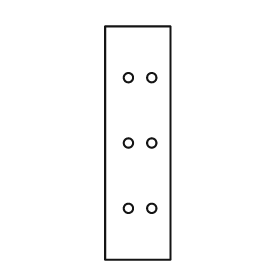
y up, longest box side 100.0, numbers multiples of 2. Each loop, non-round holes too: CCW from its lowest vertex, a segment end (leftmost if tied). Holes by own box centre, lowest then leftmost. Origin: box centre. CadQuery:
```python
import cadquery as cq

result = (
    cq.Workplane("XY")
    .moveTo(-14.0, -50.0)
    .lineTo(14.0, -50.0)
    .lineTo(14.0, 50.0)
    .lineTo(-14.0, 50.0)
    .close()
    .moveTo(-4.0, -28.0)
    .circle(2.0)
    .moveTo(6.0, -28.0)
    .circle(2.0)
    .moveTo(-4.0, 0.0)
    .circle(2.0)
    .moveTo(6.0, 0.0)
    .circle(2.0)
    .moveTo(-4.0, 28.0)
    .circle(2.0)
    .moveTo(6.0, 28.0)
    .circle(2.0)
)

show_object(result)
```